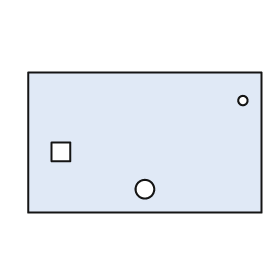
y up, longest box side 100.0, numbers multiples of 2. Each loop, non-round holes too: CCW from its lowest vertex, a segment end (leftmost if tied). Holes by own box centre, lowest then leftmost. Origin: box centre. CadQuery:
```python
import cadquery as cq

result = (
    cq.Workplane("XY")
    .moveTo(-50.0, -30.0)
    .lineTo(50.0, -30.0)
    .lineTo(50.0, 30.0)
    .lineTo(-50.0, 30.0)
    .close()
    .moveTo(0.0, -20.0)
    .circle(4.0)
    .moveTo(-40.0, -8.0)
    .lineTo(-32.0, -8.0)
    .lineTo(-32.0, 0.0)
    .lineTo(-40.0, 0.0)
    .close()
    .moveTo(42.0, 18.0)
    .circle(2.0)
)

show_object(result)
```